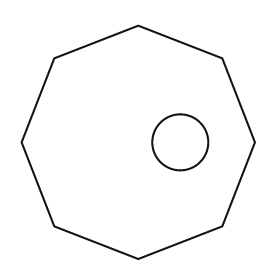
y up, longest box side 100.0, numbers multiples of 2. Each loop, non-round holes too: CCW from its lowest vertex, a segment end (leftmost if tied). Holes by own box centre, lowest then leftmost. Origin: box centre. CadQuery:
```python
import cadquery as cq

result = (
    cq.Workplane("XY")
    .moveTo(0.0, -50.0)
    .lineTo(36.0, -36.0)
    .lineTo(50.0, 0.0)
    .lineTo(36.0, 36.0)
    .lineTo(0.0, 50.0)
    .lineTo(-36.0, 36.0)
    .lineTo(-50.0, 0.0)
    .lineTo(-36.0, -36.0)
    .close()
    .moveTo(18.0, 0.0)
    .circle(12.0)
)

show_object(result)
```